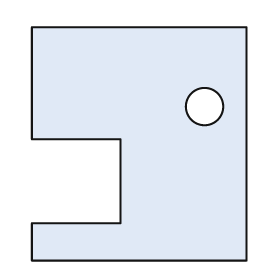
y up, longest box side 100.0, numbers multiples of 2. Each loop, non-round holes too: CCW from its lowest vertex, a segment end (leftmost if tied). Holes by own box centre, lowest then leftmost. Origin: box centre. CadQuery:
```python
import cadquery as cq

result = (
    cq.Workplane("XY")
    .moveTo(-46.0, -50.0)
    .lineTo(46.0, -50.0)
    .lineTo(46.0, 50.0)
    .lineTo(-46.0, 50.0)
    .lineTo(-46.0, 2.0)
    .lineTo(-8.0, 2.0)
    .lineTo(-8.0, -34.0)
    .lineTo(-46.0, -34.0)
    .close()
    .moveTo(28.0, 16.0)
    .circle(8.0)
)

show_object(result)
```